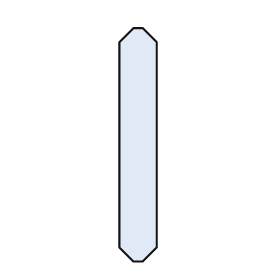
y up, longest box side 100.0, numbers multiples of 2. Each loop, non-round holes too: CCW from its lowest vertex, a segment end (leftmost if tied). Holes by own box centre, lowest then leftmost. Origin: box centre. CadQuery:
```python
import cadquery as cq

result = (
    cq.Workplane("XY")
    .moveTo(-2.0, -50.0)
    .lineTo(2.0, -50.0)
    .lineTo(8.0, -44.0)
    .lineTo(8.0, 44.0)
    .lineTo(2.0, 50.0)
    .lineTo(-2.0, 50.0)
    .lineTo(-8.0, 44.0)
    .lineTo(-8.0, -44.0)
    .close()
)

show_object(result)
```